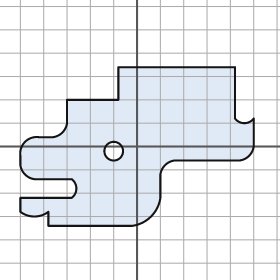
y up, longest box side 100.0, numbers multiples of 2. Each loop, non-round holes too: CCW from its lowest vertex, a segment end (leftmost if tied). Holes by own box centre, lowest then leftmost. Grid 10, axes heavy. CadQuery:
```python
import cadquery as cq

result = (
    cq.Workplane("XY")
    .moveTo(-38.0, -34.0)
    .lineTo(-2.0, -34.0)
    .threePointArc((6.0, -30.0), (10.0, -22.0))
    .lineTo(10.0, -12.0)
    .threePointArc((12.0, -8.0), (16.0, -6.0))
    .lineTo(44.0, -6.0)
    .threePointArc((48.0, -4.0), (50.0, 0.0))
    .lineTo(50.0, 12.0)
    .threePointArc((46.0, 10.0), (42.0, 12.0))
    .lineTo(42.0, 34.0)
    .lineTo(-8.0, 34.0)
    .lineTo(-8.0, 20.0)
    .lineTo(-30.0, 20.0)
    .lineTo(-30.0, 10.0)
    .threePointArc((-32.0, 6.0), (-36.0, 4.0))
    .lineTo(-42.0, 4.0)
    .threePointArc((-48.0, 2.0), (-50.0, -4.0))
    .lineTo(-50.0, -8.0)
    .threePointArc((-48.0, -12.0), (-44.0, -14.0))
    .lineTo(-28.0, -14.0)
    .threePointArc((-26.0, -18.0), (-28.0, -22.0))
    .lineTo(-50.0, -22.0)
    .lineTo(-50.0, -28.0)
    .threePointArc((-44.0, -30.0), (-38.0, -28.0))
    .close()
    .moveTo(-10.0, -2.0)
    .circle(4.0)
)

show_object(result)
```